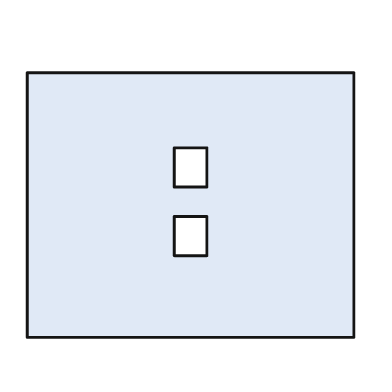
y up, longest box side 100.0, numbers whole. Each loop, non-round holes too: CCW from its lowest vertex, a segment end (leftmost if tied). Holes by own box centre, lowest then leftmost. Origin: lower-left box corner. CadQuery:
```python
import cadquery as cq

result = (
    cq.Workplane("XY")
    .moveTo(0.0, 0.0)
    .lineTo(100.0, 0.0)
    .lineTo(100.0, 81.0)
    .lineTo(0.0, 81.0)
    .close()
    .moveTo(45.0, 25.0)
    .lineTo(55.0, 25.0)
    .lineTo(55.0, 37.0)
    .lineTo(45.0, 37.0)
    .close()
    .moveTo(45.0, 46.0)
    .lineTo(55.0, 46.0)
    .lineTo(55.0, 58.0)
    .lineTo(45.0, 58.0)
    .close()
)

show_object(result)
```